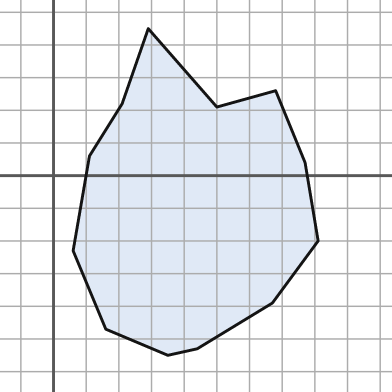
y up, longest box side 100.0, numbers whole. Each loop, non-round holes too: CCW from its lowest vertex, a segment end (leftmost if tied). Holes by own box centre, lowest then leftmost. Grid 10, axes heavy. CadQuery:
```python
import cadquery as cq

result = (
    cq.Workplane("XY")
    .moveTo(35.0, -55.0)
    .lineTo(44.0, -53.0)
    .lineTo(67.0, -39.0)
    .lineTo(81.0, -20.0)
    .lineTo(77.0, 4.0)
    .lineTo(68.0, 26.0)
    .lineTo(50.0, 21.0)
    .lineTo(29.0, 45.0)
    .lineTo(21.0, 22.0)
    .lineTo(11.0, 6.0)
    .lineTo(6.0, -23.0)
    .lineTo(16.0, -47.0)
    .close()
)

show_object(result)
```